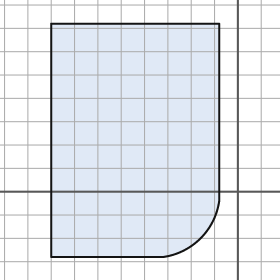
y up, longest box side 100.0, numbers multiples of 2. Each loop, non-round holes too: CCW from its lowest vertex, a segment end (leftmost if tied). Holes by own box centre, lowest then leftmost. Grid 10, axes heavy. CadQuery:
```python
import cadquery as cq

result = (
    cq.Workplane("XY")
    .moveTo(-80.0, -28.0)
    .lineTo(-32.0, -28.0)
    .threePointArc((-16.0, -20.0), (-8.0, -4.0))
    .lineTo(-8.0, 72.0)
    .lineTo(-80.0, 72.0)
    .close()
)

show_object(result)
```